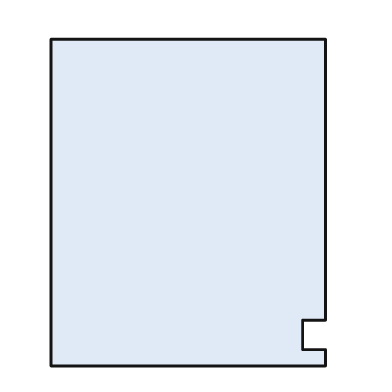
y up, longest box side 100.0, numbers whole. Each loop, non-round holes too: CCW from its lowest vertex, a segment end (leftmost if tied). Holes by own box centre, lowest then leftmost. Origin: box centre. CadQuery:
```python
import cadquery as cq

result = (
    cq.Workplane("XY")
    .moveTo(-42.0, -50.0)
    .lineTo(42.0, -50.0)
    .lineTo(42.0, -45.0)
    .lineTo(35.0, -45.0)
    .lineTo(35.0, -36.0)
    .lineTo(42.0, -36.0)
    .lineTo(42.0, 50.0)
    .lineTo(-42.0, 50.0)
    .close()
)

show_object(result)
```